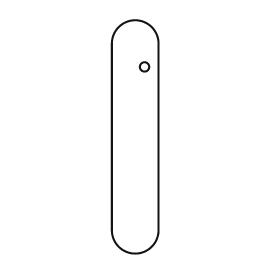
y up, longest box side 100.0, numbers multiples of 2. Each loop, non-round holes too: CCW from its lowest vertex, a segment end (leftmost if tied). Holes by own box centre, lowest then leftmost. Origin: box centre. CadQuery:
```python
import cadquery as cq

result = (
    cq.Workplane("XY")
    .moveTo(-10.0, -40.0)
    .threePointArc((0.0, -50.0), (10.0, -40.0))
    .lineTo(10.0, 40.0)
    .threePointArc((0.0, 50.0), (-10.0, 40.0))
    .close()
    .moveTo(4.0, 30.0)
    .circle(2.0)
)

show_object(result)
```